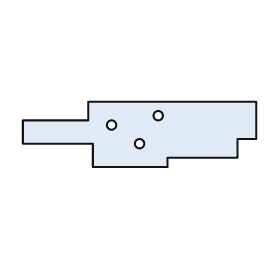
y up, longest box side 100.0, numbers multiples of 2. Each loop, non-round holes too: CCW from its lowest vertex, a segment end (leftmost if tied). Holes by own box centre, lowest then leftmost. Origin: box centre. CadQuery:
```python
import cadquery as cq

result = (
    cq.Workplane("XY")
    .moveTo(-20.0, -14.0)
    .lineTo(12.0, -14.0)
    .lineTo(12.0, -10.0)
    .lineTo(42.0, -10.0)
    .lineTo(42.0, -2.0)
    .lineTo(50.0, -2.0)
    .lineTo(50.0, 14.0)
    .lineTo(-22.0, 14.0)
    .lineTo(-22.0, 6.0)
    .lineTo(-50.0, 6.0)
    .lineTo(-50.0, -4.0)
    .lineTo(-20.0, -4.0)
    .close()
    .moveTo(0.0, -4.0)
    .circle(2.0)
    .moveTo(-12.0, 4.0)
    .circle(2.0)
    .moveTo(8.0, 8.0)
    .circle(2.0)
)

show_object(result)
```